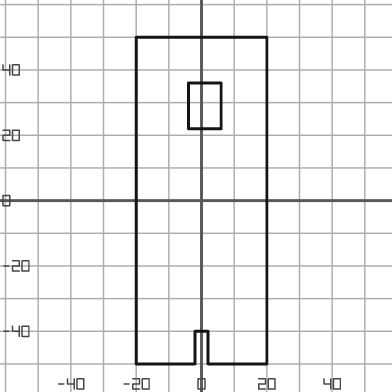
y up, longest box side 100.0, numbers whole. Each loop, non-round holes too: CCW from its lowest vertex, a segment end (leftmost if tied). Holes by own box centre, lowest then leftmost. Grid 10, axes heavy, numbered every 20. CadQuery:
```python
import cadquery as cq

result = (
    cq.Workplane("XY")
    .moveTo(-20.0, -50.0)
    .lineTo(-2.0, -50.0)
    .lineTo(-2.0, -40.0)
    .lineTo(2.0, -40.0)
    .lineTo(2.0, -50.0)
    .lineTo(20.0, -50.0)
    .lineTo(20.0, 50.0)
    .lineTo(-20.0, 50.0)
    .close()
    .moveTo(-4.0, 22.0)
    .lineTo(6.0, 22.0)
    .lineTo(6.0, 36.0)
    .lineTo(-4.0, 36.0)
    .close()
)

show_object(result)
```